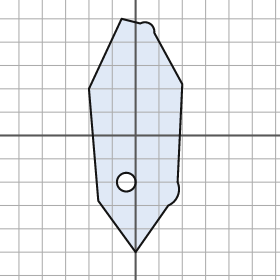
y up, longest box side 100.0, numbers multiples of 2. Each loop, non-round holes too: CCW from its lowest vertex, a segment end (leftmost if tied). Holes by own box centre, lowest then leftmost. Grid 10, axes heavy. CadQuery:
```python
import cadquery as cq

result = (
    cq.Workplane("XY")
    .moveTo(0.0, -50.0)
    .lineTo(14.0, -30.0)
    .threePointArc((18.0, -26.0), (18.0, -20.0))
    .lineTo(20.0, 22.0)
    .lineTo(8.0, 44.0)
    .threePointArc((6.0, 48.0), (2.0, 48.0))
    .lineTo(-6.0, 50.0)
    .lineTo(-20.0, 20.0)
    .lineTo(-16.0, -28.0)
    .close()
    .moveTo(-4.0, -20.0)
    .circle(4.0)
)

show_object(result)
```